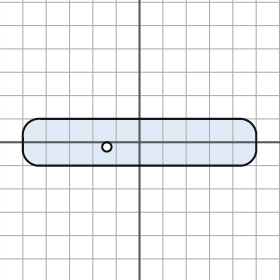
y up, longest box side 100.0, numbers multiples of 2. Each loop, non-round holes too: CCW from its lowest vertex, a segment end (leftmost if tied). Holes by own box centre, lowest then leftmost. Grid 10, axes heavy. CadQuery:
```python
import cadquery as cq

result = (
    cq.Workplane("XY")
    .moveTo(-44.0, -10.0)
    .lineTo(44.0, -10.0)
    .threePointArc((48.0, -8.0), (50.0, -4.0))
    .lineTo(50.0, 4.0)
    .threePointArc((48.0, 8.0), (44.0, 10.0))
    .lineTo(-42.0, 10.0)
    .threePointArc((-48.0, 8.0), (-50.0, 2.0))
    .lineTo(-50.0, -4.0)
    .threePointArc((-48.0, -8.0), (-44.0, -10.0))
    .close()
    .moveTo(-14.0, -2.0)
    .circle(2.0)
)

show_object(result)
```